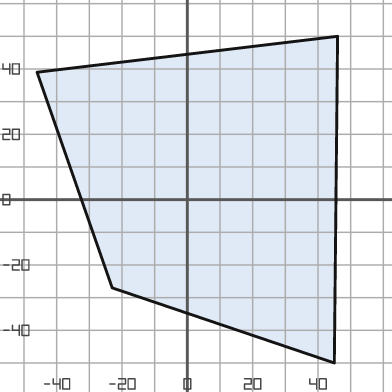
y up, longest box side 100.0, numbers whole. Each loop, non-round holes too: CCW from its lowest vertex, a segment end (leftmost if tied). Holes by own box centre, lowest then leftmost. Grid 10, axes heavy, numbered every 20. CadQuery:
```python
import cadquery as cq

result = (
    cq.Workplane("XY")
    .moveTo(45.0, -50.0)
    .lineTo(46.0, 50.0)
    .lineTo(-46.0, 39.0)
    .lineTo(-23.0, -27.0)
    .close()
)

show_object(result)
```